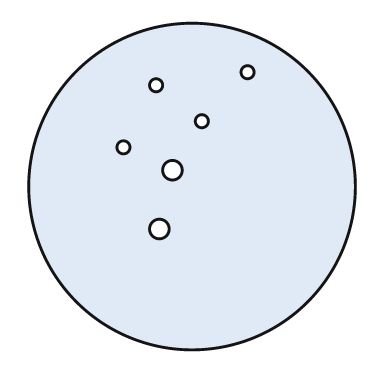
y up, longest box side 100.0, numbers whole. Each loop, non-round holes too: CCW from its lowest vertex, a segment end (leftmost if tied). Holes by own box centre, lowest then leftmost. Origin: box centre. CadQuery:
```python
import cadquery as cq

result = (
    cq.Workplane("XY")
    .moveTo(0.0, 0.0)
    .circle(50.0)
    .moveTo(-10.0, -13.0)
    .circle(3.0)
    .moveTo(-6.0, 5.0)
    .circle(3.0)
    .moveTo(-21.0, 12.0)
    .circle(2.0)
    .moveTo(3.0, 20.0)
    .circle(2.0)
    .moveTo(-11.0, 31.0)
    .circle(2.0)
    .moveTo(17.0, 35.0)
    .circle(2.0)
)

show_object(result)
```